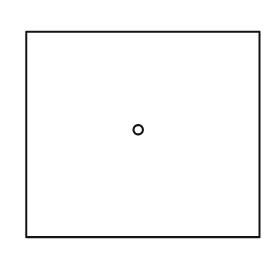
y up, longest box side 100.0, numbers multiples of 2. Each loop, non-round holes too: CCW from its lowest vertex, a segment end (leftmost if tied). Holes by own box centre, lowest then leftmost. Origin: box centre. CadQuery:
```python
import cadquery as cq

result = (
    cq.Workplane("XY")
    .moveTo(-50.0, -44.0)
    .lineTo(50.0, -44.0)
    .lineTo(50.0, 44.0)
    .lineTo(-50.0, 44.0)
    .close()
    .moveTo(-2.0, 2.0)
    .circle(2.0)
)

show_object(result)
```